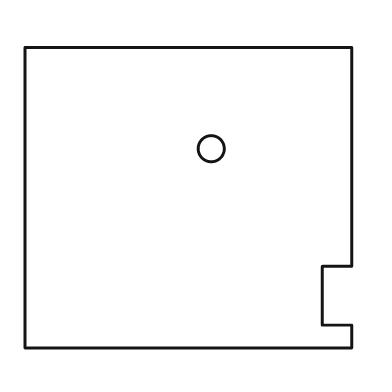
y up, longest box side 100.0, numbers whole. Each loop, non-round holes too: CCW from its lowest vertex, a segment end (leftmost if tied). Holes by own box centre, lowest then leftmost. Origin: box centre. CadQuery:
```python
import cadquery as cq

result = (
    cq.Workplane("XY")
    .moveTo(-50.0, -46.0)
    .lineTo(50.0, -46.0)
    .lineTo(50.0, -39.0)
    .lineTo(41.0, -39.0)
    .lineTo(41.0, -21.0)
    .lineTo(50.0, -21.0)
    .lineTo(50.0, 46.0)
    .lineTo(-50.0, 46.0)
    .close()
    .moveTo(7.0, 15.0)
    .circle(4.0)
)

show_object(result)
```